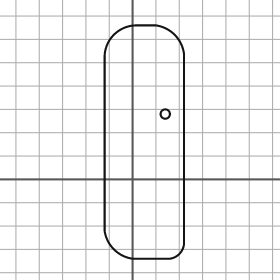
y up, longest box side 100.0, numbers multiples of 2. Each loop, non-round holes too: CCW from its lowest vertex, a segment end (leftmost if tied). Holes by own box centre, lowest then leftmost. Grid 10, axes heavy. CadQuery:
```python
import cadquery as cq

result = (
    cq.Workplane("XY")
    .moveTo(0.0, -34.0)
    .lineTo(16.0, -34.0)
    .threePointArc((20.0, -32.0), (22.0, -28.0))
    .lineTo(22.0, 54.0)
    .threePointArc((18.0, 62.0), (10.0, 66.0))
    .lineTo(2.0, 66.0)
    .threePointArc((-8.0, 62.0), (-12.0, 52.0))
    .lineTo(-12.0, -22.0)
    .threePointArc((-8.0, -30.0), (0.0, -34.0))
    .close()
    .moveTo(14.0, 28.0)
    .circle(2.0)
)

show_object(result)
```